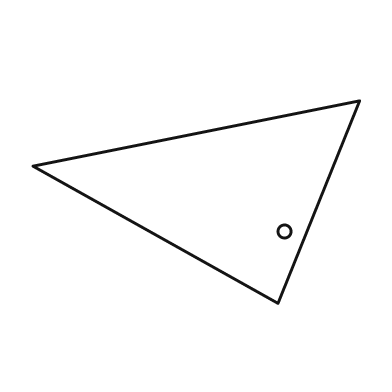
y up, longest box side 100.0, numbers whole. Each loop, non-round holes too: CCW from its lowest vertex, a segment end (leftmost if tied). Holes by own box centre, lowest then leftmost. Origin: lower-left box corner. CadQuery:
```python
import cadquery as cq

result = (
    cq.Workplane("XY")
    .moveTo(75.0, 0.0)
    .lineTo(100.0, 62.0)
    .lineTo(0.0, 42.0)
    .close()
    .moveTo(77.0, 22.0)
    .circle(2.0)
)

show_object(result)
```